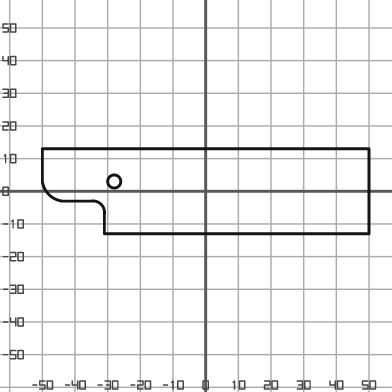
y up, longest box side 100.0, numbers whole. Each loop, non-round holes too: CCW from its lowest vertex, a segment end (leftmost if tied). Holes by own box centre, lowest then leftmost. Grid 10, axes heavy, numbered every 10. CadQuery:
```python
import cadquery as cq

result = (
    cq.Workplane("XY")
    .moveTo(-31.0, -13.0)
    .lineTo(50.0, -13.0)
    .lineTo(50.0, 13.0)
    .lineTo(-50.0, 13.0)
    .lineTo(-50.0, 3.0)
    .threePointArc((-48.0, -1.0), (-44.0, -3.0))
    .lineTo(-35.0, -3.0)
    .threePointArc((-32.0, -4.0), (-31.0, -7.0))
    .close()
    .moveTo(-28.0, 3.0)
    .circle(2.0)
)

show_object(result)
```